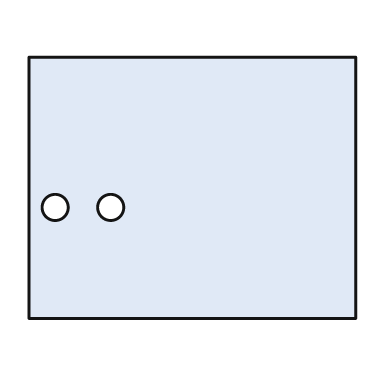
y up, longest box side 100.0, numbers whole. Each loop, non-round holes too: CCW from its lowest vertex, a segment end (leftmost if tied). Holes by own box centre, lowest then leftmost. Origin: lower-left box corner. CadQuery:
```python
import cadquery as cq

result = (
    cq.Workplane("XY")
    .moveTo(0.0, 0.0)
    .lineTo(100.0, 0.0)
    .lineTo(100.0, 80.0)
    .lineTo(0.0, 80.0)
    .close()
    .moveTo(8.0, 34.0)
    .circle(4.0)
    .moveTo(25.0, 34.0)
    .circle(4.0)
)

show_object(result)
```